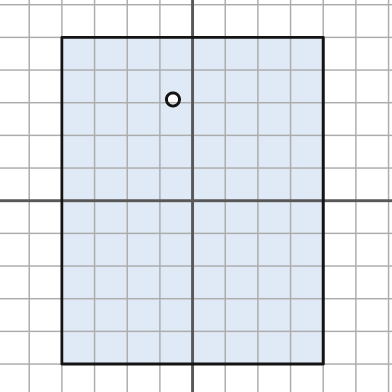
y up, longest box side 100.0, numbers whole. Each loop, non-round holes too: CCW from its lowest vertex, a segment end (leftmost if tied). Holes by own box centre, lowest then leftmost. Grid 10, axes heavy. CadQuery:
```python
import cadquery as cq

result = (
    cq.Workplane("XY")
    .moveTo(-40.0, -50.0)
    .lineTo(40.0, -50.0)
    .lineTo(40.0, 50.0)
    .lineTo(-40.0, 50.0)
    .close()
    .moveTo(-6.0, 31.0)
    .circle(2.0)
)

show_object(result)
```